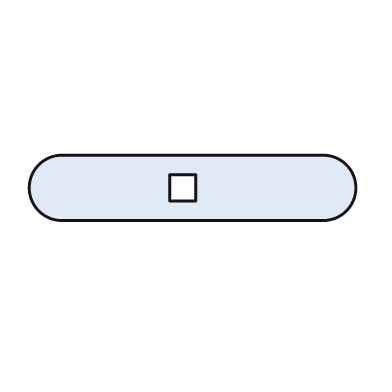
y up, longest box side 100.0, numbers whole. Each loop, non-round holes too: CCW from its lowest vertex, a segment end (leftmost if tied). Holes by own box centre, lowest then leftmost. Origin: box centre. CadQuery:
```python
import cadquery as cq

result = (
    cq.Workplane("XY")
    .moveTo(-40.0, -10.0)
    .lineTo(40.0, -10.0)
    .threePointArc((50.0, 0.0), (40.0, 10.0))
    .lineTo(-40.0, 10.0)
    .threePointArc((-50.0, 0.0), (-40.0, -10.0))
    .close()
    .moveTo(-7.0, -4.0)
    .lineTo(1.0, -4.0)
    .lineTo(1.0, 4.0)
    .lineTo(-7.0, 4.0)
    .close()
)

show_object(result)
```